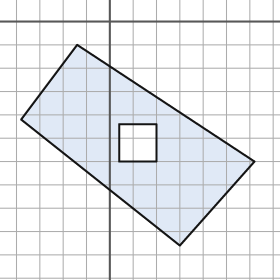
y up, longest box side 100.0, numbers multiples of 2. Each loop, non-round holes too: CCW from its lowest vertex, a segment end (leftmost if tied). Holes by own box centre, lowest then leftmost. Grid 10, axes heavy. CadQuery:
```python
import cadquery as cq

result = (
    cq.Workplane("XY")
    .moveTo(30.0, -96.0)
    .lineTo(62.0, -60.0)
    .lineTo(-14.0, -10.0)
    .lineTo(-38.0, -42.0)
    .close()
    .moveTo(4.0, -60.0)
    .lineTo(20.0, -60.0)
    .lineTo(20.0, -44.0)
    .lineTo(4.0, -44.0)
    .close()
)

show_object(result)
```